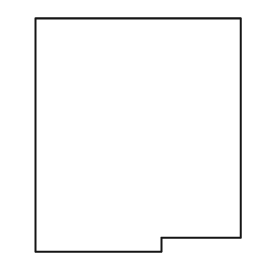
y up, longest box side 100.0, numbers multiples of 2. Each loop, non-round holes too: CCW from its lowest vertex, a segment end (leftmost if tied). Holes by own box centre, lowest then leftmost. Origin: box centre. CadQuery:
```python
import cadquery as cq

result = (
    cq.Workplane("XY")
    .moveTo(-44.0, -50.0)
    .lineTo(10.0, -50.0)
    .lineTo(10.0, -44.0)
    .lineTo(44.0, -44.0)
    .lineTo(44.0, 50.0)
    .lineTo(-44.0, 50.0)
    .close()
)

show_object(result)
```